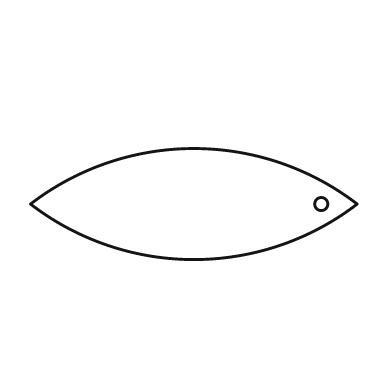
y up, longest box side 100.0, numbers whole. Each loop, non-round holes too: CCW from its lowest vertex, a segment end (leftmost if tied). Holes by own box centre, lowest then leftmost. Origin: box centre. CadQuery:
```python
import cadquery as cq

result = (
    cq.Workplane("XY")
    .moveTo(-50.0, 0.0)
    .threePointArc((0.0, -17.0), (50.0, 0.0))
    .threePointArc((0.0, 17.0), (-50.0, 0.0))
    .close()
    .moveTo(39.0, 0.0)
    .circle(2.0)
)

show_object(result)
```